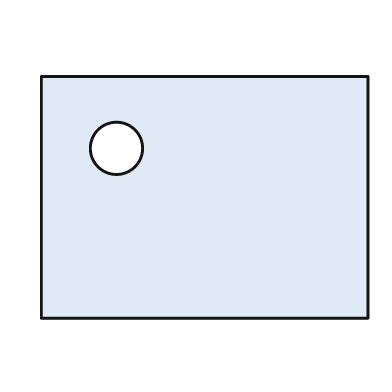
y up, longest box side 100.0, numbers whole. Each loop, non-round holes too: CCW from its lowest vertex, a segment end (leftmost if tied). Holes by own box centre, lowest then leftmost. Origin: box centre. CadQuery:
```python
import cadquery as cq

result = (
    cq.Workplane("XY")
    .moveTo(-50.0, -37.0)
    .lineTo(50.0, -37.0)
    .lineTo(50.0, 37.0)
    .lineTo(-50.0, 37.0)
    .close()
    .moveTo(-27.0, 15.0)
    .circle(8.0)
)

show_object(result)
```